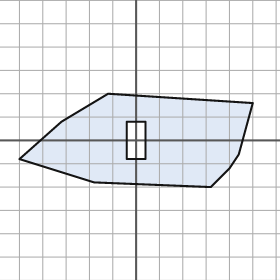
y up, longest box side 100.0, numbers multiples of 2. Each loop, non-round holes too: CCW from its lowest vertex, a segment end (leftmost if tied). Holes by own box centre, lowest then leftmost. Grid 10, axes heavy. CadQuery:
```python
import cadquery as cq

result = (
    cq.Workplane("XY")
    .moveTo(32.0, -20.0)
    .lineTo(40.0, -12.0)
    .lineTo(44.0, -6.0)
    .lineTo(50.0, 16.0)
    .lineTo(-12.0, 20.0)
    .lineTo(-32.0, 8.0)
    .lineTo(-50.0, -8.0)
    .lineTo(-18.0, -18.0)
    .close()
    .moveTo(-4.0, -8.0)
    .lineTo(4.0, -8.0)
    .lineTo(4.0, 8.0)
    .lineTo(-4.0, 8.0)
    .close()
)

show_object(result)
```